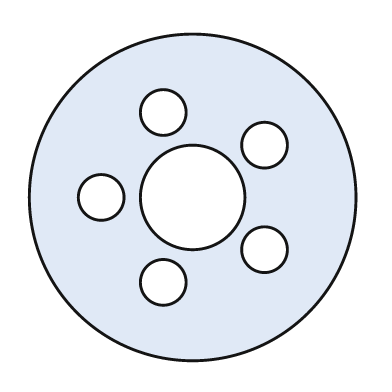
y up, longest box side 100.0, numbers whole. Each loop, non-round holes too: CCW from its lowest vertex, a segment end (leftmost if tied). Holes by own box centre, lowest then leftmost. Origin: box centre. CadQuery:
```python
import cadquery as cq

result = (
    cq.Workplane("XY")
    .moveTo(0.0, 0.0)
    .circle(50.0)
    .moveTo(-9.0, -26.0)
    .circle(7.0)
    .moveTo(22.0, -16.0)
    .circle(7.0)
    .moveTo(-28.0, 0.0)
    .circle(7.0)
    .moveTo(0.0, 0.0)
    .circle(16.0)
    .moveTo(22.0, 16.0)
    .circle(7.0)
    .moveTo(-9.0, 26.0)
    .circle(7.0)
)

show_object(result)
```